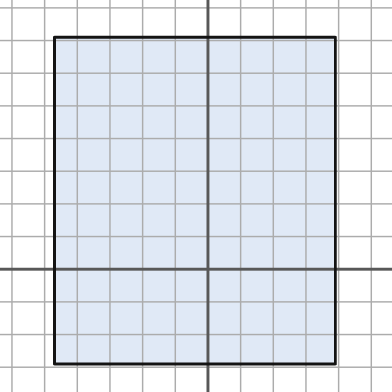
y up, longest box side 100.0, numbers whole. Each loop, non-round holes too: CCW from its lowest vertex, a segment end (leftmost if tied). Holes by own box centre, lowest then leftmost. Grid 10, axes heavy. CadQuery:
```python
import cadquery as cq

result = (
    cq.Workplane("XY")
    .moveTo(-47.0, -29.0)
    .lineTo(39.0, -29.0)
    .lineTo(39.0, 71.0)
    .lineTo(-47.0, 71.0)
    .close()
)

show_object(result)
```